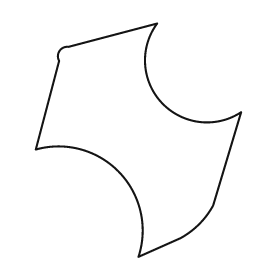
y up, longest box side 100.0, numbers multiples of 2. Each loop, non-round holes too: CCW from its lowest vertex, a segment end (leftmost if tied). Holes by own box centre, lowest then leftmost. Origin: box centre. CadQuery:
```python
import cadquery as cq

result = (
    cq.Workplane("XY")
    .moveTo(0.0, -50.0)
    .lineTo(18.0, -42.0)
    .threePointArc((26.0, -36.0), (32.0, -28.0))
    .lineTo(44.0, 12.0)
    .threePointArc((10.0, 16.0), (8.0, 50.0))
    .lineTo(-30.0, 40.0)
    .threePointArc((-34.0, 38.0), (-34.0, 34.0))
    .lineTo(-44.0, -4.0)
    .threePointArc((-8.0, -14.0), (0.0, -50.0))
    .close()
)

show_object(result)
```